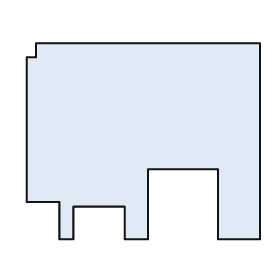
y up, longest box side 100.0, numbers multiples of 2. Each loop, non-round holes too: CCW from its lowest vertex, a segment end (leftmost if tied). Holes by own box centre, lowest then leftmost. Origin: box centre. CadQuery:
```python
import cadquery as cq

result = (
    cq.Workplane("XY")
    .moveTo(-36.0, -42.0)
    .lineTo(-30.0, -42.0)
    .lineTo(-30.0, -28.0)
    .lineTo(-8.0, -28.0)
    .lineTo(-8.0, -42.0)
    .lineTo(2.0, -42.0)
    .lineTo(2.0, -12.0)
    .lineTo(32.0, -12.0)
    .lineTo(32.0, -42.0)
    .lineTo(50.0, -42.0)
    .lineTo(50.0, 42.0)
    .lineTo(-46.0, 42.0)
    .lineTo(-46.0, 36.0)
    .lineTo(-50.0, 36.0)
    .lineTo(-50.0, -26.0)
    .lineTo(-36.0, -26.0)
    .close()
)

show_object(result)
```